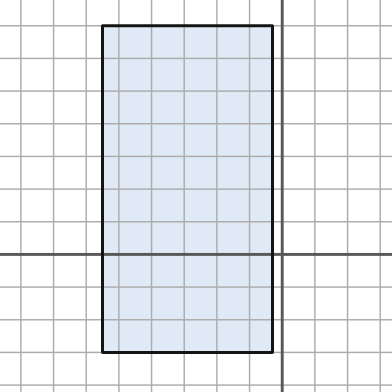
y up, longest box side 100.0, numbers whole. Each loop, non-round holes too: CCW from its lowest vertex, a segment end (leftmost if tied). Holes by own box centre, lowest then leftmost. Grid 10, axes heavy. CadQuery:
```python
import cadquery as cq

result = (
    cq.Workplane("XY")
    .moveTo(-55.0, -30.0)
    .lineTo(-3.0, -30.0)
    .lineTo(-3.0, 70.0)
    .lineTo(-55.0, 70.0)
    .close()
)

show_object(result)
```